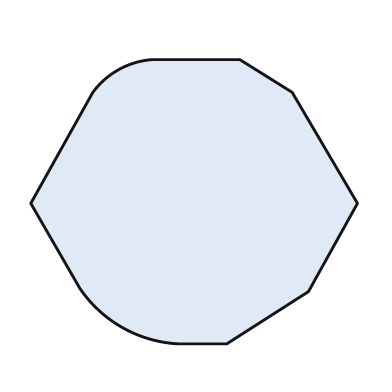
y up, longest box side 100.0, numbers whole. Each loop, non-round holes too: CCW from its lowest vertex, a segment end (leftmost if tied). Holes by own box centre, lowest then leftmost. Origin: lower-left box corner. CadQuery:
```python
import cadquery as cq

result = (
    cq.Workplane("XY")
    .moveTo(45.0, 0.0)
    .lineTo(60.0, 0.0)
    .lineTo(85.0, 16.0)
    .lineTo(100.0, 43.0)
    .lineTo(80.0, 77.0)
    .lineTo(64.0, 87.0)
    .lineTo(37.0, 87.0)
    .threePointArc((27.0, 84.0), (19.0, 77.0))
    .lineTo(0.0, 43.0)
    .lineTo(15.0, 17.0)
    .threePointArc((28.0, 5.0), (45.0, 0.0))
    .close()
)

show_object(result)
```